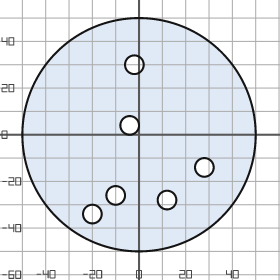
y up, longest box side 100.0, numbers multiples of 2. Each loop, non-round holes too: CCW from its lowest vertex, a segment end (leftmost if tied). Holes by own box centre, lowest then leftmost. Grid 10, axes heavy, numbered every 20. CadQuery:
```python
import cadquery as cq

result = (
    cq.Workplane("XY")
    .moveTo(0.0, 0.0)
    .circle(50.0)
    .moveTo(-20.0, -34.0)
    .circle(4.0)
    .moveTo(12.0, -28.0)
    .circle(4.0)
    .moveTo(-10.0, -26.0)
    .circle(4.0)
    .moveTo(28.0, -14.0)
    .circle(4.0)
    .moveTo(-4.0, 4.0)
    .circle(4.0)
    .moveTo(-2.0, 30.0)
    .circle(4.0)
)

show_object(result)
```